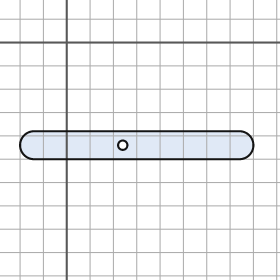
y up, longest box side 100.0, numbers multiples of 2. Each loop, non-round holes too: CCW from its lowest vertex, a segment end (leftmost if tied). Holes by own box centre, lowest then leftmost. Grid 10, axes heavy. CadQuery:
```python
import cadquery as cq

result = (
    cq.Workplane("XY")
    .moveTo(-14.0, -50.0)
    .lineTo(74.0, -50.0)
    .threePointArc((80.0, -44.0), (74.0, -38.0))
    .lineTo(-14.0, -38.0)
    .threePointArc((-20.0, -44.0), (-14.0, -50.0))
    .close()
    .moveTo(24.0, -44.0)
    .circle(2.0)
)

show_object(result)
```